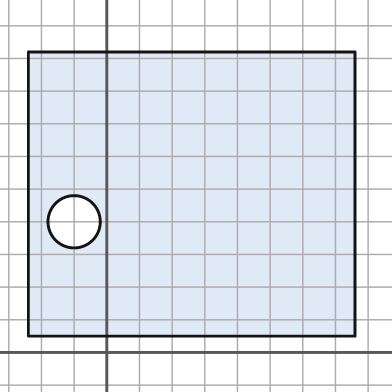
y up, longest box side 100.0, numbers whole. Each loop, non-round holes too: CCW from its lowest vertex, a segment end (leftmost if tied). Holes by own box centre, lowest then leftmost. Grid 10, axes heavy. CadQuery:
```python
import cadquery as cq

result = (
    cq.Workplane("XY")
    .moveTo(-24.0, 5.0)
    .lineTo(76.0, 5.0)
    .lineTo(76.0, 92.0)
    .lineTo(-24.0, 92.0)
    .close()
    .moveTo(-10.0, 40.0)
    .circle(8.0)
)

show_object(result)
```